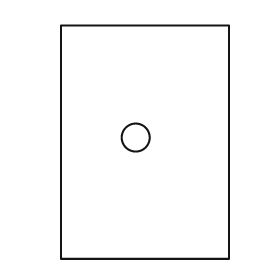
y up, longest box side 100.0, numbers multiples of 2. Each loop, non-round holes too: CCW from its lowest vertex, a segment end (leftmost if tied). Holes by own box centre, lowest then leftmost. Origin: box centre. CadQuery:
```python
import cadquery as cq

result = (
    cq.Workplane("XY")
    .moveTo(-36.0, -50.0)
    .lineTo(36.0, -50.0)
    .lineTo(36.0, 50.0)
    .lineTo(-36.0, 50.0)
    .close()
    .moveTo(-4.0, 2.0)
    .circle(6.0)
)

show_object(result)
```